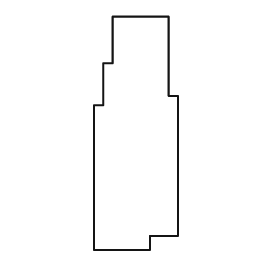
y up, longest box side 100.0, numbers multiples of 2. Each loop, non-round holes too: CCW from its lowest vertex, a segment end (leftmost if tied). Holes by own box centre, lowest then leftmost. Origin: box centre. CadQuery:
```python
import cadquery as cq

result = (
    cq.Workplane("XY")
    .moveTo(-18.0, -50.0)
    .lineTo(6.0, -50.0)
    .lineTo(6.0, -44.0)
    .lineTo(18.0, -44.0)
    .lineTo(18.0, 16.0)
    .lineTo(14.0, 16.0)
    .lineTo(14.0, 50.0)
    .lineTo(-10.0, 50.0)
    .lineTo(-10.0, 30.0)
    .lineTo(-14.0, 30.0)
    .lineTo(-14.0, 12.0)
    .lineTo(-18.0, 12.0)
    .close()
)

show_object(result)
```